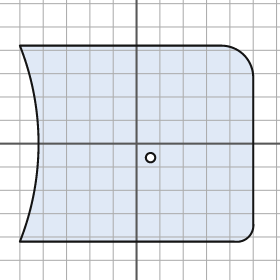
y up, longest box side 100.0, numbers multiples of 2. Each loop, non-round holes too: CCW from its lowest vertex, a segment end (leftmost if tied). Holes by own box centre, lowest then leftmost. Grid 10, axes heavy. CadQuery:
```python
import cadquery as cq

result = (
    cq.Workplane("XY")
    .moveTo(-50.0, -42.0)
    .lineTo(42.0, -42.0)
    .threePointArc((48.0, -40.0), (50.0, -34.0))
    .lineTo(50.0, 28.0)
    .threePointArc((46.0, 38.0), (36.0, 42.0))
    .lineTo(-50.0, 42.0)
    .threePointArc((-42.0, 0.0), (-50.0, -42.0))
    .close()
    .moveTo(6.0, -6.0)
    .circle(2.0)
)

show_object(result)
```